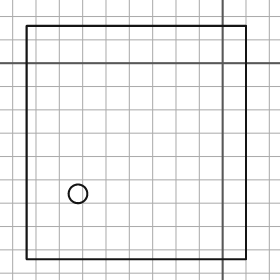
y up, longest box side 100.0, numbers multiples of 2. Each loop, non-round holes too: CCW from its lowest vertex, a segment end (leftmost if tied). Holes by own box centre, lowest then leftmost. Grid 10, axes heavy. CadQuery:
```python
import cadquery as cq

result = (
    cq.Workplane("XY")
    .moveTo(-84.0, -84.0)
    .lineTo(10.0, -84.0)
    .lineTo(10.0, 16.0)
    .lineTo(-84.0, 16.0)
    .close()
    .moveTo(-62.0, -56.0)
    .circle(4.0)
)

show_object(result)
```